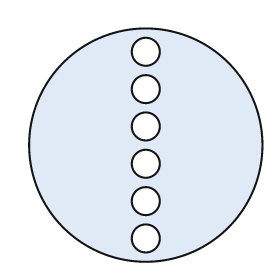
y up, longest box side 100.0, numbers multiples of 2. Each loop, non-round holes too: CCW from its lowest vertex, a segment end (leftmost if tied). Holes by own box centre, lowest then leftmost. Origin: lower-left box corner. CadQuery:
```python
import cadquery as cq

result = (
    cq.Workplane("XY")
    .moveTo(50.0, 50.0)
    .circle(50.0)
    .moveTo(50.0, 10.0)
    .circle(6.0)
    .moveTo(50.0, 26.0)
    .circle(6.0)
    .moveTo(50.0, 42.0)
    .circle(6.0)
    .moveTo(50.0, 58.0)
    .circle(6.0)
    .moveTo(50.0, 74.0)
    .circle(6.0)
    .moveTo(50.0, 90.0)
    .circle(6.0)
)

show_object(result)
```